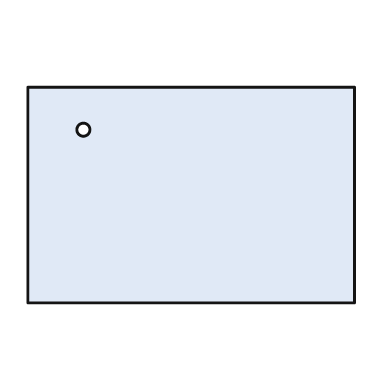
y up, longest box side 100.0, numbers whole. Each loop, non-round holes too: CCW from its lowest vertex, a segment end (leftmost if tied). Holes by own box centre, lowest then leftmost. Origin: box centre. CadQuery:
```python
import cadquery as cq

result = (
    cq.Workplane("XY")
    .moveTo(-50.0, -33.0)
    .lineTo(50.0, -33.0)
    .lineTo(50.0, 33.0)
    .lineTo(-50.0, 33.0)
    .close()
    .moveTo(-33.0, 20.0)
    .circle(2.0)
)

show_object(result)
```